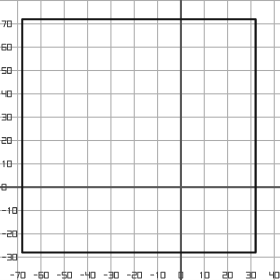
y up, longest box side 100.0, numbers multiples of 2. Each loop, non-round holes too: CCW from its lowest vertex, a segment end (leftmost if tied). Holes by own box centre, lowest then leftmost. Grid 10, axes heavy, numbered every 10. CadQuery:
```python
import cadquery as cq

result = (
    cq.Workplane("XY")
    .moveTo(-68.0, -28.0)
    .lineTo(32.0, -28.0)
    .lineTo(32.0, 72.0)
    .lineTo(-68.0, 72.0)
    .close()
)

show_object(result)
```